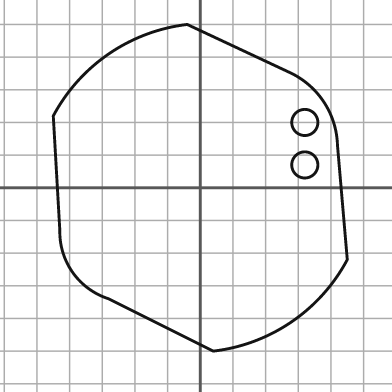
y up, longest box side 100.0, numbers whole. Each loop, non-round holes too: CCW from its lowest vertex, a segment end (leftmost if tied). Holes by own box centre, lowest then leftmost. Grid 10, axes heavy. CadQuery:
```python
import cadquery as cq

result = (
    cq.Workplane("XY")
    .moveTo(4.0, -50.0)
    .threePointArc((28.0, -41.0), (45.0, -22.0))
    .lineTo(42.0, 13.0)
    .threePointArc((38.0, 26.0), (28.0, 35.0))
    .lineTo(-4.0, 50.0)
    .threePointArc((-28.0, 41.0), (-45.0, 22.0))
    .lineTo(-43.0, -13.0)
    .threePointArc((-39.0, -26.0), (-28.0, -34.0))
    .close()
    .moveTo(32.0, 7.0)
    .circle(4.0)
    .moveTo(32.0, 20.0)
    .circle(4.0)
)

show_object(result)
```